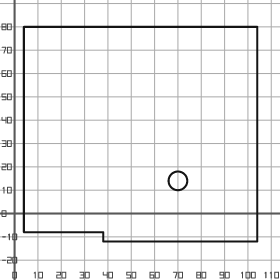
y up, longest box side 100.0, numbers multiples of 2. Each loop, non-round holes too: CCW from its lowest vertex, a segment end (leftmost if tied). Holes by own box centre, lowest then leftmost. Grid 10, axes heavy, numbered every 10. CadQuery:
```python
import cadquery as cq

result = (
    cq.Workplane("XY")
    .moveTo(38.0, -12.0)
    .lineTo(104.0, -12.0)
    .lineTo(104.0, 80.0)
    .lineTo(4.0, 80.0)
    .lineTo(4.0, -8.0)
    .lineTo(38.0, -8.0)
    .close()
    .moveTo(70.0, 14.0)
    .circle(4.0)
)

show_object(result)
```